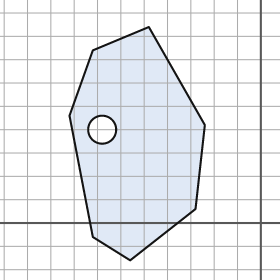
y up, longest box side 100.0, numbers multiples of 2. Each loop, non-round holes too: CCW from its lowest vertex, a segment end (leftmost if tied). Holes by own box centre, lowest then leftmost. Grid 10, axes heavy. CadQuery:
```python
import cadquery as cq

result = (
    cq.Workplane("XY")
    .moveTo(-56.0, -16.0)
    .lineTo(-28.0, 6.0)
    .lineTo(-24.0, 42.0)
    .lineTo(-48.0, 84.0)
    .lineTo(-72.0, 74.0)
    .lineTo(-82.0, 46.0)
    .lineTo(-72.0, -6.0)
    .close()
    .moveTo(-68.0, 40.0)
    .circle(6.0)
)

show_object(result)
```